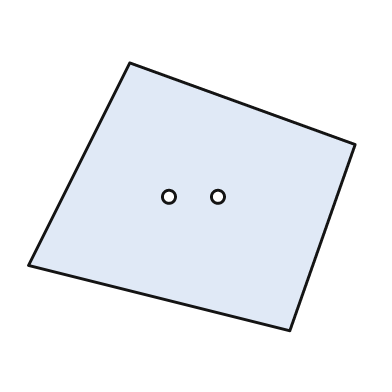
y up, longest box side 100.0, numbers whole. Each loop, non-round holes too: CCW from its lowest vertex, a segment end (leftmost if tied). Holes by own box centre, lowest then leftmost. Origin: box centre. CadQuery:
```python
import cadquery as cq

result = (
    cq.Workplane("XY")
    .moveTo(30.0, -41.0)
    .lineTo(50.0, 16.0)
    .lineTo(-19.0, 41.0)
    .lineTo(-50.0, -21.0)
    .close()
    .moveTo(-7.0, 0.0)
    .circle(2.0)
    .moveTo(8.0, 0.0)
    .circle(2.0)
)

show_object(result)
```